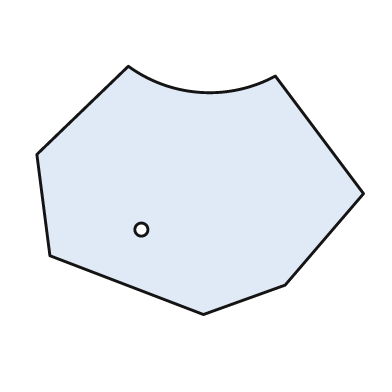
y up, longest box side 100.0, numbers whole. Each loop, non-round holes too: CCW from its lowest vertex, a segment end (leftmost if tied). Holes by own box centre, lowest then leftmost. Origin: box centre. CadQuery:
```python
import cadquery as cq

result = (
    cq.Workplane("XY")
    .moveTo(1.0, -38.0)
    .lineTo(26.0, -29.0)
    .lineTo(50.0, -1.0)
    .lineTo(23.0, 35.0)
    .threePointArc((0.0, 30.0), (-22.0, 38.0))
    .lineTo(-50.0, 11.0)
    .lineTo(-46.0, -20.0)
    .close()
    .moveTo(-18.0, -12.0)
    .circle(2.0)
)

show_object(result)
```